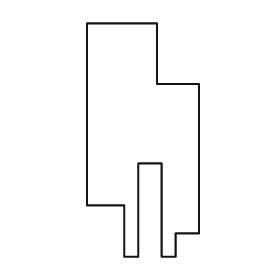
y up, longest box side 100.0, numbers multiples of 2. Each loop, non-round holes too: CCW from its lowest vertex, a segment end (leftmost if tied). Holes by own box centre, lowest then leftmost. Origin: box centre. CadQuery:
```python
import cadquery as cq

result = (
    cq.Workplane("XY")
    .moveTo(-8.0, -50.0)
    .lineTo(-2.0, -50.0)
    .lineTo(-2.0, -10.0)
    .lineTo(8.0, -10.0)
    .lineTo(8.0, -50.0)
    .lineTo(14.0, -50.0)
    .lineTo(14.0, -40.0)
    .lineTo(24.0, -40.0)
    .lineTo(24.0, 24.0)
    .lineTo(6.0, 24.0)
    .lineTo(6.0, 50.0)
    .lineTo(-24.0, 50.0)
    .lineTo(-24.0, -28.0)
    .lineTo(-8.0, -28.0)
    .close()
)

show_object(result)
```